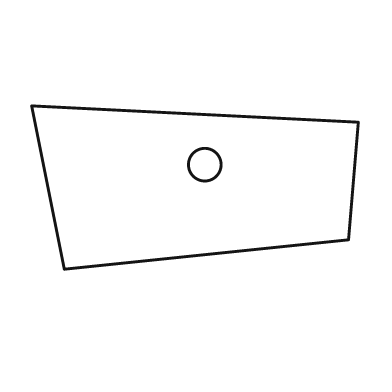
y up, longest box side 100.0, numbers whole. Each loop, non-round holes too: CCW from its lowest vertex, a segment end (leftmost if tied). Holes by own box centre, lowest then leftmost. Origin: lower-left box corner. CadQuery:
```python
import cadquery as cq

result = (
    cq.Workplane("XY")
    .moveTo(10.0, 0.0)
    .lineTo(97.0, 9.0)
    .lineTo(100.0, 45.0)
    .lineTo(0.0, 50.0)
    .close()
    .moveTo(53.0, 32.0)
    .circle(5.0)
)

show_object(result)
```